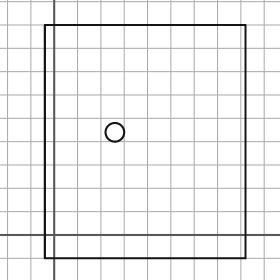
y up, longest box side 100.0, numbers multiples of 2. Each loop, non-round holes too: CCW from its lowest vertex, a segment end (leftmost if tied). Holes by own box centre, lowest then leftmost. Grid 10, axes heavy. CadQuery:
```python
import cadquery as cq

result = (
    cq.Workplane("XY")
    .moveTo(-4.0, -10.0)
    .lineTo(82.0, -10.0)
    .lineTo(82.0, 90.0)
    .lineTo(-4.0, 90.0)
    .close()
    .moveTo(26.0, 44.0)
    .circle(4.0)
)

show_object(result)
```